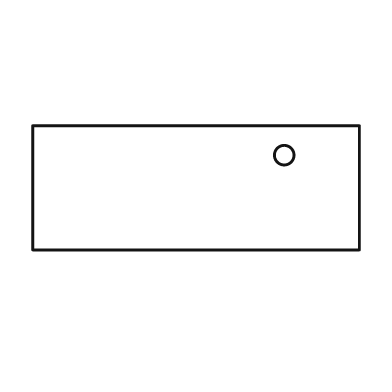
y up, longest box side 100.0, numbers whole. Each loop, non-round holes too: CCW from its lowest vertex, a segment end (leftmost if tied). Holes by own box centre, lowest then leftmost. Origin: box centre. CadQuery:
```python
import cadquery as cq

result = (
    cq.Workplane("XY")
    .moveTo(-50.0, -19.0)
    .lineTo(50.0, -19.0)
    .lineTo(50.0, 19.0)
    .lineTo(-50.0, 19.0)
    .close()
    .moveTo(27.0, 10.0)
    .circle(3.0)
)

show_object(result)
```